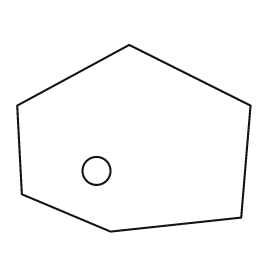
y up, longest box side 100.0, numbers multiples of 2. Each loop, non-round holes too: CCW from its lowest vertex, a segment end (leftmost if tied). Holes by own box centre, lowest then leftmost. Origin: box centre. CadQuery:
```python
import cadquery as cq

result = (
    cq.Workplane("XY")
    .moveTo(-10.0, -40.0)
    .lineTo(46.0, -34.0)
    .lineTo(50.0, 14.0)
    .lineTo(-2.0, 40.0)
    .lineTo(-50.0, 14.0)
    .lineTo(-48.0, -24.0)
    .close()
    .moveTo(-16.0, -14.0)
    .circle(6.0)
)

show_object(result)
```